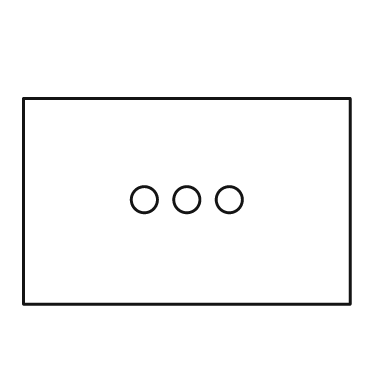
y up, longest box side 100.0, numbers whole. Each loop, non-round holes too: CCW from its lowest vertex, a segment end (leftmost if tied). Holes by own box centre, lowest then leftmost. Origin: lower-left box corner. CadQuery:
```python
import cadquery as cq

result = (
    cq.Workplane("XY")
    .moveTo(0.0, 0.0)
    .lineTo(100.0, 0.0)
    .lineTo(100.0, 63.0)
    .lineTo(0.0, 63.0)
    .close()
    .moveTo(37.0, 32.0)
    .circle(4.0)
    .moveTo(50.0, 32.0)
    .circle(4.0)
    .moveTo(63.0, 32.0)
    .circle(4.0)
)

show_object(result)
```